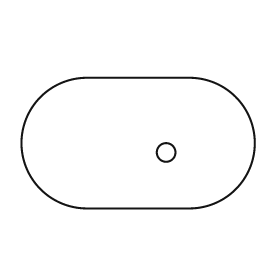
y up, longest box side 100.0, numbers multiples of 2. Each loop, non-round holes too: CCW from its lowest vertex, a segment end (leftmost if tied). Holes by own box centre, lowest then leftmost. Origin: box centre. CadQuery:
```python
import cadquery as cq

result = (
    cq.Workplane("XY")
    .moveTo(-22.0, -28.0)
    .lineTo(22.0, -28.0)
    .threePointArc((50.0, 0.0), (22.0, 28.0))
    .lineTo(-22.0, 28.0)
    .threePointArc((-50.0, 0.0), (-22.0, -28.0))
    .close()
    .moveTo(12.0, -4.0)
    .circle(4.0)
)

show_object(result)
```